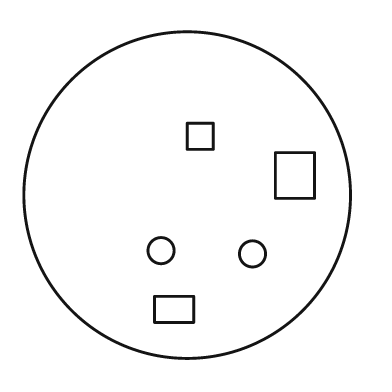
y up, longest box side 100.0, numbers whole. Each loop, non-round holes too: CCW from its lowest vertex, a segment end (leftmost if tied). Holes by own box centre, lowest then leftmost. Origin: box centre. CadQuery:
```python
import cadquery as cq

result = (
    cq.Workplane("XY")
    .moveTo(0.0, 0.0)
    .circle(50.0)
    .moveTo(-10.0, -39.0)
    .lineTo(2.0, -39.0)
    .lineTo(2.0, -31.0)
    .lineTo(-10.0, -31.0)
    .close()
    .moveTo(20.0, -18.0)
    .circle(4.0)
    .moveTo(-8.0, -17.0)
    .circle(4.0)
    .moveTo(27.0, -1.0)
    .lineTo(39.0, -1.0)
    .lineTo(39.0, 13.0)
    .lineTo(27.0, 13.0)
    .close()
    .moveTo(0.0, 14.0)
    .lineTo(8.0, 14.0)
    .lineTo(8.0, 22.0)
    .lineTo(0.0, 22.0)
    .close()
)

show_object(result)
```